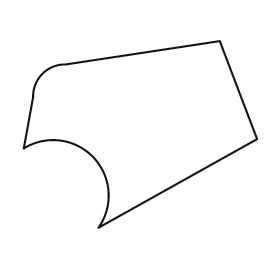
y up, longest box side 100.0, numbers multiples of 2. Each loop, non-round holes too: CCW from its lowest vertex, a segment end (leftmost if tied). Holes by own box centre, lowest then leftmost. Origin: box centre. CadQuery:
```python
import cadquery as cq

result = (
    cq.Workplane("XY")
    .moveTo(-18.0, -40.0)
    .lineTo(50.0, -2.0)
    .lineTo(34.0, 40.0)
    .lineTo(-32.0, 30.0)
    .threePointArc((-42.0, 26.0), (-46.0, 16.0))
    .lineTo(-50.0, -6.0)
    .threePointArc((-20.0, -10.0), (-18.0, -40.0))
    .close()
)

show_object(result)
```